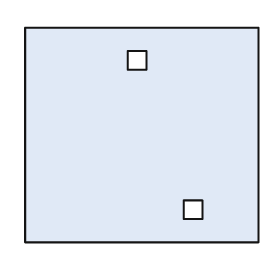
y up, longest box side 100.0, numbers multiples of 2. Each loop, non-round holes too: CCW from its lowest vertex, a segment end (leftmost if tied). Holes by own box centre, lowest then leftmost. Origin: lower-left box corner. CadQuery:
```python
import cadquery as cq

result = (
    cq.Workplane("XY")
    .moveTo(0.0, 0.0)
    .lineTo(100.0, 0.0)
    .lineTo(100.0, 92.0)
    .lineTo(0.0, 92.0)
    .close()
    .moveTo(68.0, 10.0)
    .lineTo(76.0, 10.0)
    .lineTo(76.0, 18.0)
    .lineTo(68.0, 18.0)
    .close()
    .moveTo(44.0, 74.0)
    .lineTo(52.0, 74.0)
    .lineTo(52.0, 82.0)
    .lineTo(44.0, 82.0)
    .close()
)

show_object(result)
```